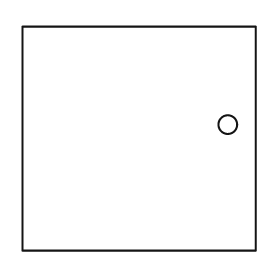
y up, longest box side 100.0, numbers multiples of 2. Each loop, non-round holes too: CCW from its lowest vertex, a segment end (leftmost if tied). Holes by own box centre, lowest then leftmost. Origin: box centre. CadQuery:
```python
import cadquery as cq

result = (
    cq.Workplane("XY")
    .moveTo(-50.0, -48.0)
    .lineTo(50.0, -48.0)
    .lineTo(50.0, 48.0)
    .lineTo(-50.0, 48.0)
    .close()
    .moveTo(38.0, 6.0)
    .circle(4.0)
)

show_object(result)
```